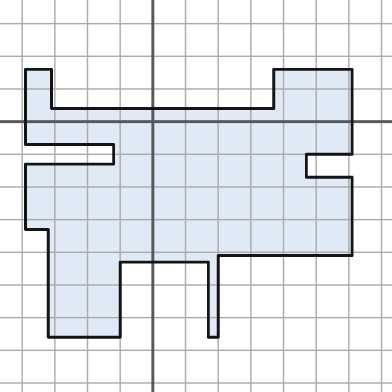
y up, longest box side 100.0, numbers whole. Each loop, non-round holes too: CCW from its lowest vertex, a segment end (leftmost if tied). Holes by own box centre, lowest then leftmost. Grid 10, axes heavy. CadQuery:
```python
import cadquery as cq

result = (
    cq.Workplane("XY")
    .moveTo(-32.0, -66.0)
    .lineTo(-10.0, -66.0)
    .lineTo(-10.0, -43.0)
    .lineTo(17.0, -43.0)
    .lineTo(17.0, -66.0)
    .lineTo(20.0, -66.0)
    .lineTo(20.0, -41.0)
    .lineTo(61.0, -41.0)
    .lineTo(61.0, -17.0)
    .lineTo(47.0, -17.0)
    .lineTo(47.0, -10.0)
    .lineTo(61.0, -10.0)
    .lineTo(61.0, 16.0)
    .lineTo(37.0, 16.0)
    .lineTo(37.0, 4.0)
    .lineTo(-31.0, 4.0)
    .lineTo(-31.0, 16.0)
    .lineTo(-39.0, 16.0)
    .lineTo(-39.0, -7.0)
    .lineTo(-12.0, -7.0)
    .lineTo(-12.0, -13.0)
    .lineTo(-39.0, -13.0)
    .lineTo(-39.0, -33.0)
    .lineTo(-32.0, -33.0)
    .close()
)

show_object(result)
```